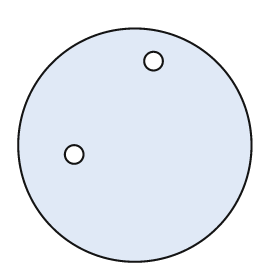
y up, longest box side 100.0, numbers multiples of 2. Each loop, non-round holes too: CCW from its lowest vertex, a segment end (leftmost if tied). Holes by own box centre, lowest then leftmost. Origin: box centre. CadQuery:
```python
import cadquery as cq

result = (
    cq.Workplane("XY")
    .moveTo(0.0, 0.0)
    .circle(50.0)
    .moveTo(-26.0, -4.0)
    .circle(4.0)
    .moveTo(8.0, 36.0)
    .circle(4.0)
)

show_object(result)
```